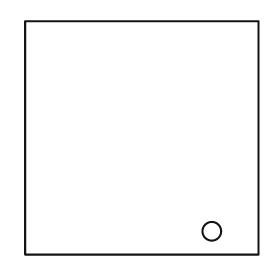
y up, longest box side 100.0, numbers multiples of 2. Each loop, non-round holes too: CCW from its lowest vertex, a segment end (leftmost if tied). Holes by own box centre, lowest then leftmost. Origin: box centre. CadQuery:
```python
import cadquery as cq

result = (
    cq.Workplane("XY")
    .moveTo(-50.0, -50.0)
    .lineTo(50.0, -50.0)
    .lineTo(50.0, 50.0)
    .lineTo(-50.0, 50.0)
    .close()
    .moveTo(30.0, -40.0)
    .circle(4.0)
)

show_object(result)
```